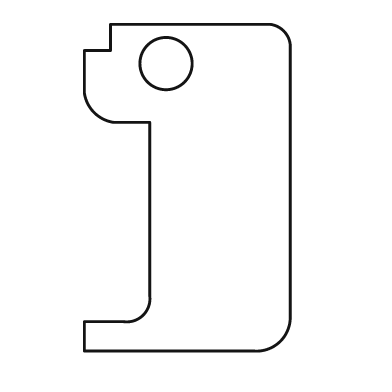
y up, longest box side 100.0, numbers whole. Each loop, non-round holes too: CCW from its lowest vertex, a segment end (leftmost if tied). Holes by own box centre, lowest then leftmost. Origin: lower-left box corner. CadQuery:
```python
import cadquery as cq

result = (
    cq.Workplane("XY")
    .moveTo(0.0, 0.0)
    .lineTo(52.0, 0.0)
    .threePointArc((60.0, 3.0), (63.0, 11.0))
    .lineTo(63.0, 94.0)
    .threePointArc((61.0, 98.0), (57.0, 100.0))
    .lineTo(8.0, 100.0)
    .lineTo(8.0, 92.0)
    .lineTo(0.0, 92.0)
    .lineTo(0.0, 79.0)
    .threePointArc((3.0, 73.0), (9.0, 70.0))
    .lineTo(20.0, 70.0)
    .lineTo(20.0, 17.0)
    .threePointArc((18.0, 11.0), (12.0, 9.0))
    .lineTo(0.0, 9.0)
    .close()
    .moveTo(25.0, 88.0)
    .circle(8.0)
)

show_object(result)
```